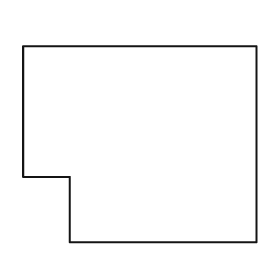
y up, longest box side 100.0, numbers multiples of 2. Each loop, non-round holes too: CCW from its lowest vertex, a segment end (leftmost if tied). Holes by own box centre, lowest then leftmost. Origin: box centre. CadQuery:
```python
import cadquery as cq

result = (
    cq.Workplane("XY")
    .moveTo(-30.0, -42.0)
    .lineTo(50.0, -42.0)
    .lineTo(50.0, 42.0)
    .lineTo(-50.0, 42.0)
    .lineTo(-50.0, -14.0)
    .lineTo(-30.0, -14.0)
    .close()
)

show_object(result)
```